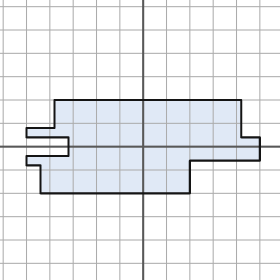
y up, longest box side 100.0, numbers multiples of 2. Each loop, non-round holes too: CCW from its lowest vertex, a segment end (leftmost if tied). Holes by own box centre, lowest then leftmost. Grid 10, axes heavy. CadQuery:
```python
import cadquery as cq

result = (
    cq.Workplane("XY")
    .moveTo(-44.0, -20.0)
    .lineTo(20.0, -20.0)
    .lineTo(20.0, -6.0)
    .lineTo(50.0, -6.0)
    .lineTo(50.0, 4.0)
    .lineTo(42.0, 4.0)
    .lineTo(42.0, 20.0)
    .lineTo(-38.0, 20.0)
    .lineTo(-38.0, 8.0)
    .lineTo(-50.0, 8.0)
    .lineTo(-50.0, 4.0)
    .lineTo(-32.0, 4.0)
    .lineTo(-32.0, -4.0)
    .lineTo(-50.0, -4.0)
    .lineTo(-50.0, -8.0)
    .lineTo(-44.0, -8.0)
    .close()
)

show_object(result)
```